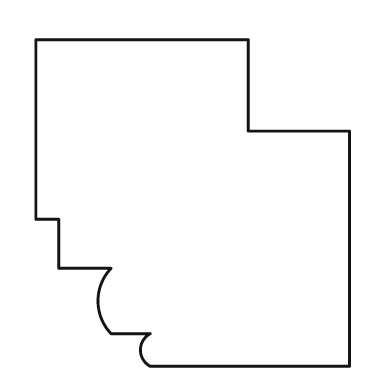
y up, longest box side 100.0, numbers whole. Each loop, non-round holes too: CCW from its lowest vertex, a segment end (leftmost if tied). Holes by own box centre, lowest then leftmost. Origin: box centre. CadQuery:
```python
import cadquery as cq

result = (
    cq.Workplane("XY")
    .moveTo(-13.0, -50.0)
    .lineTo(48.0, -50.0)
    .lineTo(48.0, 22.0)
    .lineTo(17.0, 22.0)
    .lineTo(17.0, 50.0)
    .lineTo(-48.0, 50.0)
    .lineTo(-48.0, -5.0)
    .lineTo(-41.0, -5.0)
    .lineTo(-41.0, -20.0)
    .lineTo(-25.0, -20.0)
    .threePointArc((-29.0, -30.0), (-25.0, -40.0))
    .lineTo(-13.0, -40.0)
    .threePointArc((-16.0, -45.0), (-13.0, -50.0))
    .close()
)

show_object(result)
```